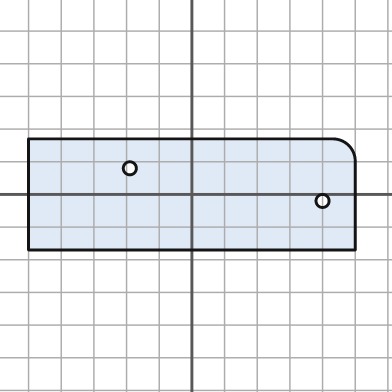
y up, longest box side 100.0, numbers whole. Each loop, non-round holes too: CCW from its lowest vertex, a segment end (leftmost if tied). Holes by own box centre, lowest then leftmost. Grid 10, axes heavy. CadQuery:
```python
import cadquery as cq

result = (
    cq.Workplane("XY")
    .moveTo(-50.0, -17.0)
    .lineTo(50.0, -17.0)
    .lineTo(50.0, 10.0)
    .threePointArc((48.0, 15.0), (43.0, 17.0))
    .lineTo(-50.0, 17.0)
    .close()
    .moveTo(40.0, -2.0)
    .circle(2.0)
    .moveTo(-19.0, 8.0)
    .circle(2.0)
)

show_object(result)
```